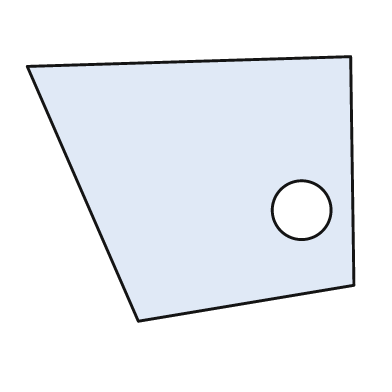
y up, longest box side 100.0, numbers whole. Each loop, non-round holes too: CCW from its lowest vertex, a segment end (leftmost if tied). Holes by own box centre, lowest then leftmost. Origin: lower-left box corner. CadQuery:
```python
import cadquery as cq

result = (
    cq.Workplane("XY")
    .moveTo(34.0, 0.0)
    .lineTo(100.0, 11.0)
    .lineTo(99.0, 81.0)
    .lineTo(0.0, 78.0)
    .close()
    .moveTo(84.0, 34.0)
    .circle(9.0)
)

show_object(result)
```